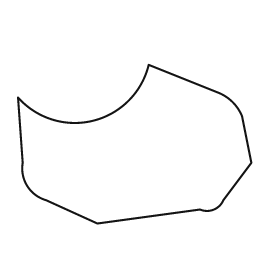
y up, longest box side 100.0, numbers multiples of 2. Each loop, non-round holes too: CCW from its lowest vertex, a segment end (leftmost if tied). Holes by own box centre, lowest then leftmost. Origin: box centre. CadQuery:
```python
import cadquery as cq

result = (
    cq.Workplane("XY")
    .moveTo(-16.0, -34.0)
    .lineTo(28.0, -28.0)
    .threePointArc((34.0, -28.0), (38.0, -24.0))
    .lineTo(50.0, -8.0)
    .lineTo(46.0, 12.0)
    .threePointArc((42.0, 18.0), (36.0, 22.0))
    .lineTo(6.0, 34.0)
    .threePointArc((-18.0, 10.0), (-50.0, 20.0))
    .lineTo(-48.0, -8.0)
    .threePointArc((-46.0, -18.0), (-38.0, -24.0))
    .close()
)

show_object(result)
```